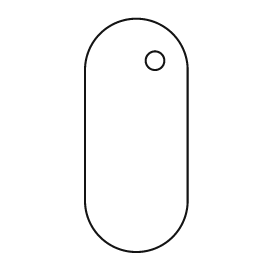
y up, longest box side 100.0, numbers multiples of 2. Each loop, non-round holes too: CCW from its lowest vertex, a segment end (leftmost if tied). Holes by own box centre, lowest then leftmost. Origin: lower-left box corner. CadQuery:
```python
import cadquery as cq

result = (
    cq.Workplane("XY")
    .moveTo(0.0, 22.0)
    .threePointArc((22.0, 0.0), (44.0, 22.0))
    .lineTo(44.0, 78.0)
    .threePointArc((22.0, 100.0), (0.0, 78.0))
    .close()
    .moveTo(30.0, 82.0)
    .circle(4.0)
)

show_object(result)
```